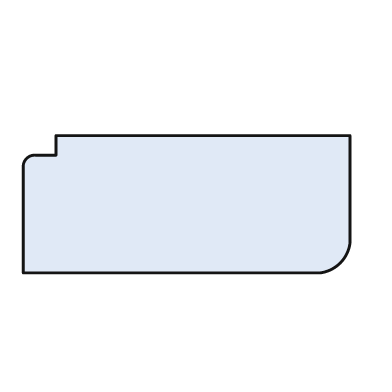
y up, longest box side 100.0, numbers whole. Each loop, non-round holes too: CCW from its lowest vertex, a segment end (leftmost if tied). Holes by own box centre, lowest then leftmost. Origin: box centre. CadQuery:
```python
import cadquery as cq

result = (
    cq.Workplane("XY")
    .moveTo(-50.0, -21.0)
    .lineTo(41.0, -21.0)
    .threePointArc((47.0, -18.0), (50.0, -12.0))
    .lineTo(50.0, 21.0)
    .lineTo(-40.0, 21.0)
    .lineTo(-40.0, 15.0)
    .lineTo(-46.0, 15.0)
    .threePointArc((-49.0, 14.0), (-50.0, 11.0))
    .close()
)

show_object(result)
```